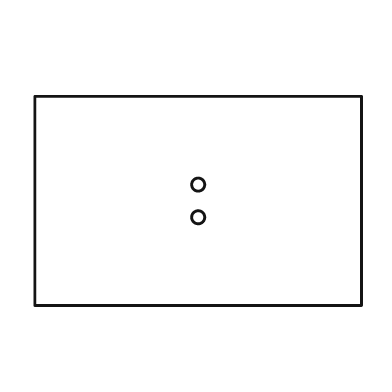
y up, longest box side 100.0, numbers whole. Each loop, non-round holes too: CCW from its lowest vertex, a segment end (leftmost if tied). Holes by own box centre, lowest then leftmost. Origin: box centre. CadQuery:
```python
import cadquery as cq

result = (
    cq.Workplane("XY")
    .moveTo(-50.0, -32.0)
    .lineTo(50.0, -32.0)
    .lineTo(50.0, 32.0)
    .lineTo(-50.0, 32.0)
    .close()
    .moveTo(0.0, -5.0)
    .circle(2.0)
    .moveTo(0.0, 5.0)
    .circle(2.0)
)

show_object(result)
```